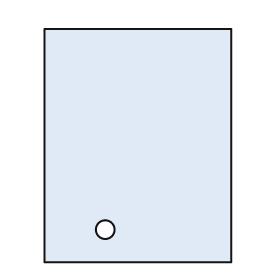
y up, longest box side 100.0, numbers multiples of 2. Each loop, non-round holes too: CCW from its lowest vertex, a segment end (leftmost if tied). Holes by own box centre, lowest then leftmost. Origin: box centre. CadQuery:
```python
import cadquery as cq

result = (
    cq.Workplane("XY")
    .moveTo(-40.0, -50.0)
    .lineTo(40.0, -50.0)
    .lineTo(40.0, 50.0)
    .lineTo(-40.0, 50.0)
    .close()
    .moveTo(-14.0, -36.0)
    .circle(4.0)
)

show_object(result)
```